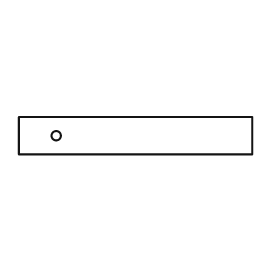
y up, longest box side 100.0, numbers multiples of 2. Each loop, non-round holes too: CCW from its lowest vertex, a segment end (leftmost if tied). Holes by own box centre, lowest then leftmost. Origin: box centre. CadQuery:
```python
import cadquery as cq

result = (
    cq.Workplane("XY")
    .moveTo(-50.0, -8.0)
    .lineTo(50.0, -8.0)
    .lineTo(50.0, 8.0)
    .lineTo(-50.0, 8.0)
    .close()
    .moveTo(-34.0, 0.0)
    .circle(2.0)
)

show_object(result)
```